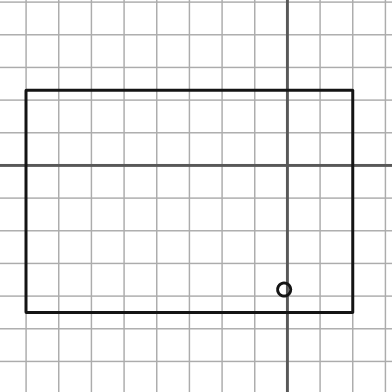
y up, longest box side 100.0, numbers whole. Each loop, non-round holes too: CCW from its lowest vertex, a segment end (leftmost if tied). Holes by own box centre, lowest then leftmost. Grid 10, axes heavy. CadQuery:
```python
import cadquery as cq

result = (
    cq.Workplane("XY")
    .moveTo(-80.0, -45.0)
    .lineTo(20.0, -45.0)
    .lineTo(20.0, 23.0)
    .lineTo(-80.0, 23.0)
    .close()
    .moveTo(-1.0, -38.0)
    .circle(2.0)
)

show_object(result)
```